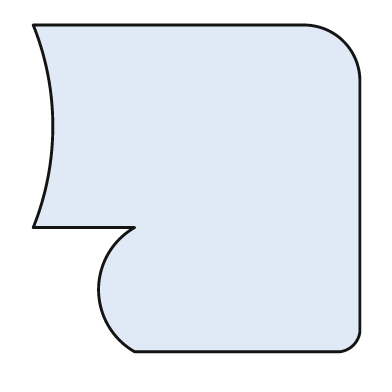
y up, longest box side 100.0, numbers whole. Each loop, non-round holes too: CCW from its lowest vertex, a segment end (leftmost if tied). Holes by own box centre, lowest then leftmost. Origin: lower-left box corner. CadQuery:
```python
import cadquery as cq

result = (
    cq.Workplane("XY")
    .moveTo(31.0, 0.0)
    .lineTo(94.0, 0.0)
    .threePointArc((98.0, 2.0), (100.0, 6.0))
    .lineTo(100.0, 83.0)
    .threePointArc((95.0, 95.0), (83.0, 100.0))
    .lineTo(0.0, 100.0)
    .threePointArc((6.0, 69.0), (0.0, 38.0))
    .lineTo(31.0, 38.0)
    .threePointArc((20.0, 19.0), (31.0, 0.0))
    .close()
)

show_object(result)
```